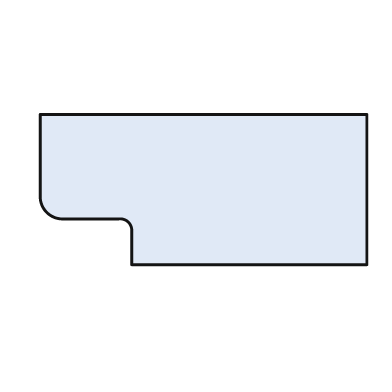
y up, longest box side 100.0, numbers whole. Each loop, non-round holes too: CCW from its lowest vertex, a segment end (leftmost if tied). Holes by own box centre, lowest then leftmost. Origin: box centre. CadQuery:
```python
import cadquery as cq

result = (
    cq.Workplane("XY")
    .moveTo(-22.0, -23.0)
    .lineTo(50.0, -23.0)
    .lineTo(50.0, 23.0)
    .lineTo(-50.0, 23.0)
    .lineTo(-50.0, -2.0)
    .threePointArc((-48.0, -7.0), (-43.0, -9.0))
    .lineTo(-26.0, -9.0)
    .threePointArc((-23.0, -10.0), (-22.0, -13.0))
    .close()
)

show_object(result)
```